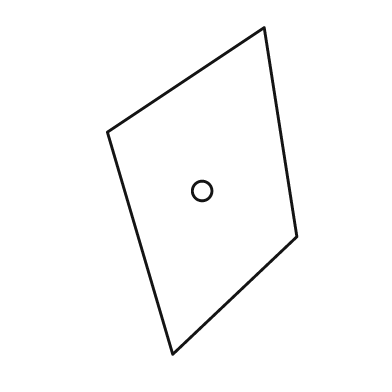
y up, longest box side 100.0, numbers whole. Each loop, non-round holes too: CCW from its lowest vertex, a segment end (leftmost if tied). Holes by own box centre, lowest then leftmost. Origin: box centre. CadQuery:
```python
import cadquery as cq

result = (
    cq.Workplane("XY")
    .moveTo(-9.0, -50.0)
    .lineTo(29.0, -14.0)
    .lineTo(19.0, 50.0)
    .lineTo(-29.0, 18.0)
    .close()
    .moveTo(0.0, 0.0)
    .circle(3.0)
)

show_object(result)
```